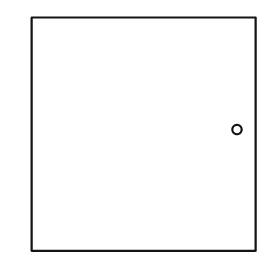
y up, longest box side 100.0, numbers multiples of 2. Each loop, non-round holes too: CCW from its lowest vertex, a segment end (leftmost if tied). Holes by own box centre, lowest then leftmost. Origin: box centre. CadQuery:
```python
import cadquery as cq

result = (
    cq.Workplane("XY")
    .moveTo(-48.0, -50.0)
    .lineTo(48.0, -50.0)
    .lineTo(48.0, 50.0)
    .lineTo(-48.0, 50.0)
    .close()
    .moveTo(40.0, 2.0)
    .circle(2.0)
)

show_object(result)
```